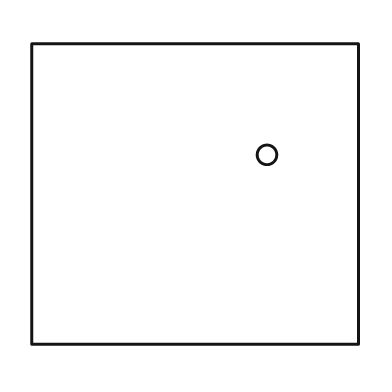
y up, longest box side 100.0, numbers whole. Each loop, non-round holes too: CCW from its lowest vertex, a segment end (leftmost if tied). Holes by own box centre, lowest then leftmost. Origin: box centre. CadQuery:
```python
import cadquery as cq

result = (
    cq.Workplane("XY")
    .moveTo(-50.0, -46.0)
    .lineTo(50.0, -46.0)
    .lineTo(50.0, 46.0)
    .lineTo(-50.0, 46.0)
    .close()
    .moveTo(22.0, 12.0)
    .circle(3.0)
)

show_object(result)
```